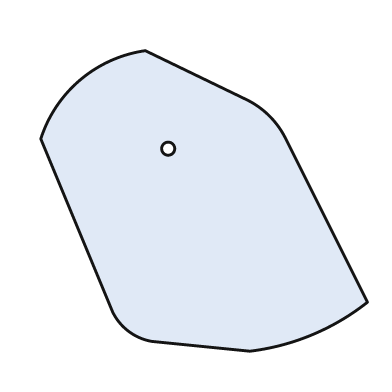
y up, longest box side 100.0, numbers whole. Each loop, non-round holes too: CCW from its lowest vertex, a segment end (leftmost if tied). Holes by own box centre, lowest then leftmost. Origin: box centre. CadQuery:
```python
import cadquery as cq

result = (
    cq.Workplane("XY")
    .moveTo(14.0, -46.0)
    .threePointArc((33.0, -41.0), (50.0, -31.0))
    .lineTo(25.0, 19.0)
    .threePointArc((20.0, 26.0), (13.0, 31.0))
    .lineTo(-18.0, 46.0)
    .threePointArc((-38.0, 37.0), (-50.0, 19.0))
    .lineTo(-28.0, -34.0)
    .threePointArc((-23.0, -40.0), (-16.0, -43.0))
    .close()
    .moveTo(-11.0, 16.0)
    .circle(2.0)
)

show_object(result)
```